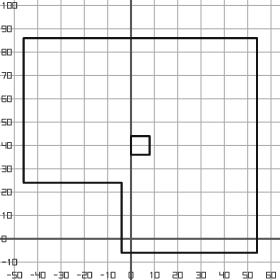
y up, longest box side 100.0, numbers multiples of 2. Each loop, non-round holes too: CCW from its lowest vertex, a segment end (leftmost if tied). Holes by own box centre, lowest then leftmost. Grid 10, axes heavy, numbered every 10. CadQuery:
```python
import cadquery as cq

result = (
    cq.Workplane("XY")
    .moveTo(-4.0, -6.0)
    .lineTo(54.0, -6.0)
    .lineTo(54.0, 86.0)
    .lineTo(-46.0, 86.0)
    .lineTo(-46.0, 24.0)
    .lineTo(-4.0, 24.0)
    .close()
    .moveTo(0.0, 36.0)
    .lineTo(8.0, 36.0)
    .lineTo(8.0, 44.0)
    .lineTo(0.0, 44.0)
    .close()
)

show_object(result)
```